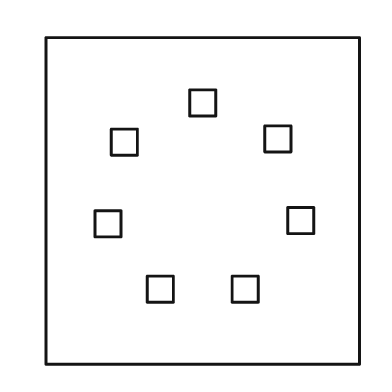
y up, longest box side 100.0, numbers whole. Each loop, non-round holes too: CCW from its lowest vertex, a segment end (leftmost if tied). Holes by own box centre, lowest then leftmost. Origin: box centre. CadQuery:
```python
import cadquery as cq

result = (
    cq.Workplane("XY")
    .moveTo(-48.0, -50.0)
    .lineTo(48.0, -50.0)
    .lineTo(48.0, 50.0)
    .lineTo(-48.0, 50.0)
    .close()
    .moveTo(-17.0, -31.0)
    .lineTo(-9.0, -31.0)
    .lineTo(-9.0, -23.0)
    .lineTo(-17.0, -23.0)
    .close()
    .moveTo(9.0, -31.0)
    .lineTo(17.0, -31.0)
    .lineTo(17.0, -23.0)
    .lineTo(9.0, -23.0)
    .close()
    .moveTo(-33.0, -11.0)
    .lineTo(-25.0, -11.0)
    .lineTo(-25.0, -3.0)
    .lineTo(-33.0, -3.0)
    .close()
    .moveTo(26.0, -10.0)
    .lineTo(34.0, -10.0)
    .lineTo(34.0, -2.0)
    .lineTo(26.0, -2.0)
    .close()
    .moveTo(-28.0, 14.0)
    .lineTo(-20.0, 14.0)
    .lineTo(-20.0, 22.0)
    .lineTo(-28.0, 22.0)
    .close()
    .moveTo(19.0, 15.0)
    .lineTo(27.0, 15.0)
    .lineTo(27.0, 23.0)
    .lineTo(19.0, 23.0)
    .close()
    .moveTo(-4.0, 26.0)
    .lineTo(4.0, 26.0)
    .lineTo(4.0, 34.0)
    .lineTo(-4.0, 34.0)
    .close()
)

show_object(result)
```